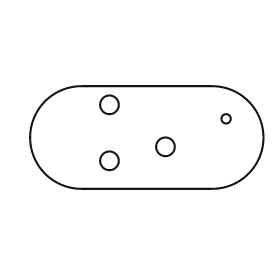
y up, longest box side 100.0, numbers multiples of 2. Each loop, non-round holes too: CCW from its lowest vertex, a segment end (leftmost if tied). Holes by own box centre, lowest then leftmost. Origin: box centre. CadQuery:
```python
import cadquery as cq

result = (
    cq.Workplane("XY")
    .moveTo(-28.0, -22.0)
    .lineTo(28.0, -22.0)
    .threePointArc((50.0, 0.0), (28.0, 22.0))
    .lineTo(-28.0, 22.0)
    .threePointArc((-50.0, 0.0), (-28.0, -22.0))
    .close()
    .moveTo(-16.0, -10.0)
    .circle(4.0)
    .moveTo(8.0, -4.0)
    .circle(4.0)
    .moveTo(34.0, 8.0)
    .circle(2.0)
    .moveTo(-16.0, 14.0)
    .circle(4.0)
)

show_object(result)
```